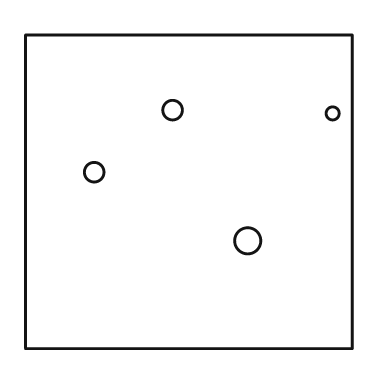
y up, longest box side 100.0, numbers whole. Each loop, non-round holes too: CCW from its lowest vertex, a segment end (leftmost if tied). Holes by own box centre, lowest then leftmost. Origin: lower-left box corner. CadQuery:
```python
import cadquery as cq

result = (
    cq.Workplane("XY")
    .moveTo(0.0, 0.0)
    .lineTo(100.0, 0.0)
    .lineTo(100.0, 96.0)
    .lineTo(0.0, 96.0)
    .close()
    .moveTo(68.0, 33.0)
    .circle(4.0)
    .moveTo(21.0, 54.0)
    .circle(3.0)
    .moveTo(94.0, 72.0)
    .circle(2.0)
    .moveTo(45.0, 73.0)
    .circle(3.0)
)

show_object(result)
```